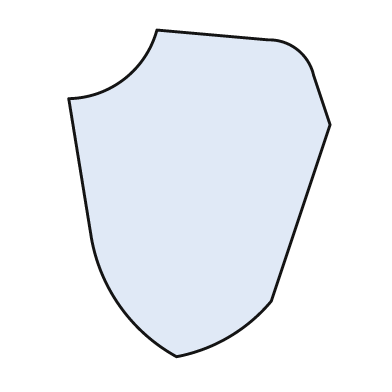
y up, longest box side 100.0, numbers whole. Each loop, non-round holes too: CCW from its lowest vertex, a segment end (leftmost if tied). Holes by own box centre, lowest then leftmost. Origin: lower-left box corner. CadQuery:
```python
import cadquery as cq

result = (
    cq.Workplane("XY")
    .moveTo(33.0, 0.0)
    .threePointArc((49.0, 6.0), (62.0, 17.0))
    .lineTo(80.0, 71.0)
    .lineTo(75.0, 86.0)
    .threePointArc((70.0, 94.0), (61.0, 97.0))
    .lineTo(27.0, 100.0)
    .threePointArc((17.0, 85.0), (0.0, 79.0))
    .lineTo(7.0, 36.0)
    .threePointArc((16.0, 15.0), (33.0, 0.0))
    .close()
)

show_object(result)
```